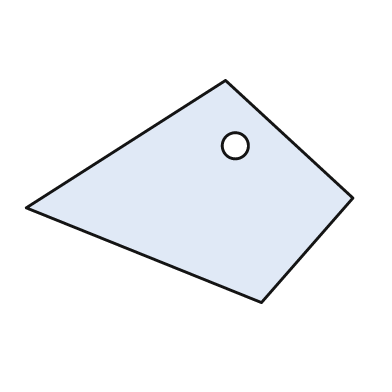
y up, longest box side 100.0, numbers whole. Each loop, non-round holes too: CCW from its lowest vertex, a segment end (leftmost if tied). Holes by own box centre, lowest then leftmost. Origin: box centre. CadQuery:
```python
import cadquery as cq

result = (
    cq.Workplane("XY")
    .moveTo(22.0, -34.0)
    .lineTo(50.0, -2.0)
    .lineTo(11.0, 34.0)
    .lineTo(-50.0, -5.0)
    .close()
    .moveTo(14.0, 14.0)
    .circle(4.0)
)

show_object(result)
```